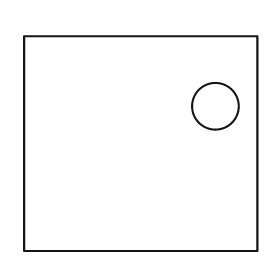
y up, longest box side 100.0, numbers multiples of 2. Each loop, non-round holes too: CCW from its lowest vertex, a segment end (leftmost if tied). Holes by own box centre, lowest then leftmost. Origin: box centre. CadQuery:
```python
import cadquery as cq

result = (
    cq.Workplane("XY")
    .moveTo(-50.0, -46.0)
    .lineTo(50.0, -46.0)
    .lineTo(50.0, 46.0)
    .lineTo(-50.0, 46.0)
    .close()
    .moveTo(32.0, 16.0)
    .circle(10.0)
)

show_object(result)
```